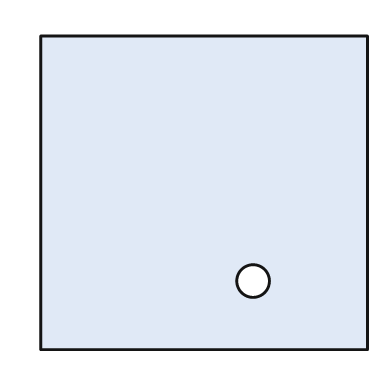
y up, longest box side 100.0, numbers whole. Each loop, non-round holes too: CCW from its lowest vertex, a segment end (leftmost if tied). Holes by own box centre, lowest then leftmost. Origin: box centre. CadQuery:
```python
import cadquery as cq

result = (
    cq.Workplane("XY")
    .moveTo(-50.0, -48.0)
    .lineTo(50.0, -48.0)
    .lineTo(50.0, 48.0)
    .lineTo(-50.0, 48.0)
    .close()
    .moveTo(15.0, -27.0)
    .circle(5.0)
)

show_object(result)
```